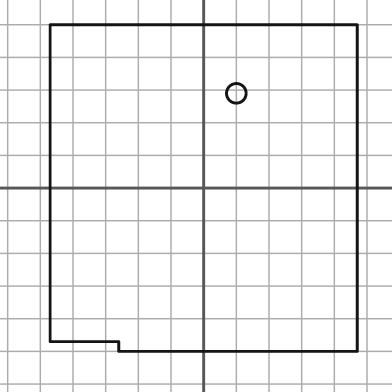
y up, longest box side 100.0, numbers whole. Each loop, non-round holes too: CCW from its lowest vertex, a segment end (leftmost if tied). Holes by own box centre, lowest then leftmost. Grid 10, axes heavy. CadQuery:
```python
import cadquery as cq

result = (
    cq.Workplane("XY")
    .moveTo(-26.0, -50.0)
    .lineTo(47.0, -50.0)
    .lineTo(47.0, 50.0)
    .lineTo(-47.0, 50.0)
    .lineTo(-47.0, -47.0)
    .lineTo(-26.0, -47.0)
    .close()
    .moveTo(10.0, 29.0)
    .circle(3.0)
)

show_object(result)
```